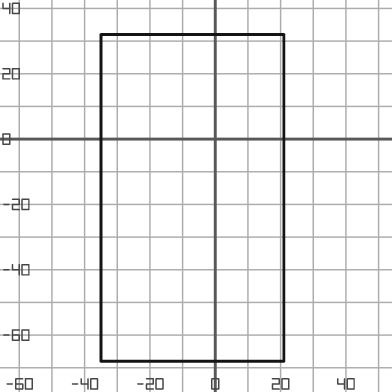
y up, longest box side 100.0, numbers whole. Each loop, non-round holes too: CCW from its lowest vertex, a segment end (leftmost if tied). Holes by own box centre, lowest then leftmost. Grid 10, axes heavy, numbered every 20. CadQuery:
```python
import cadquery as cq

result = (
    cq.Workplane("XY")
    .moveTo(-35.0, -68.0)
    .lineTo(21.0, -68.0)
    .lineTo(21.0, 32.0)
    .lineTo(-35.0, 32.0)
    .close()
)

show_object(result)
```